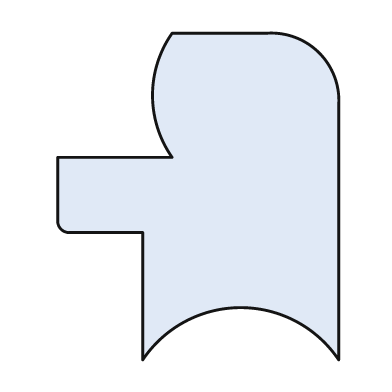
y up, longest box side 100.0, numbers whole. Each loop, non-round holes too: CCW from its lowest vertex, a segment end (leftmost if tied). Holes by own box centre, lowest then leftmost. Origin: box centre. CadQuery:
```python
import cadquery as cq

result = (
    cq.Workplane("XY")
    .moveTo(-17.0, -50.0)
    .threePointArc((13.0, -34.0), (43.0, -50.0))
    .lineTo(43.0, 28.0)
    .threePointArc((37.0, 44.0), (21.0, 50.0))
    .lineTo(-8.0, 50.0)
    .threePointArc((-14.0, 31.0), (-8.0, 12.0))
    .lineTo(-43.0, 12.0)
    .lineTo(-43.0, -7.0)
    .threePointArc((-42.0, -10.0), (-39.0, -11.0))
    .lineTo(-17.0, -11.0)
    .close()
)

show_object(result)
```